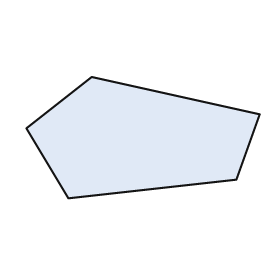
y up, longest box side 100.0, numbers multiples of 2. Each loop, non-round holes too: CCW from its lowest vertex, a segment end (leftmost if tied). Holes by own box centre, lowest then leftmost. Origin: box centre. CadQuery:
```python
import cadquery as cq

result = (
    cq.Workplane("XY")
    .moveTo(-32.0, -26.0)
    .lineTo(40.0, -18.0)
    .lineTo(50.0, 10.0)
    .lineTo(-22.0, 26.0)
    .lineTo(-50.0, 4.0)
    .close()
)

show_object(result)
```